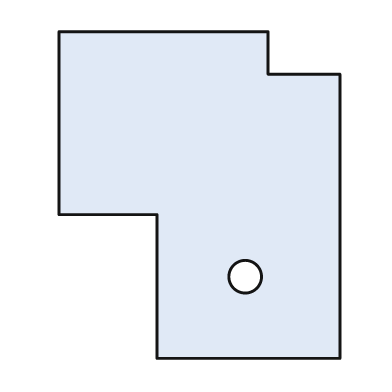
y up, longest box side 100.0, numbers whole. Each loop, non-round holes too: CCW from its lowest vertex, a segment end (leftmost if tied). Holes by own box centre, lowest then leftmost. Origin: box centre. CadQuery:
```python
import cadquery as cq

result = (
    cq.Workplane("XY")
    .moveTo(-13.0, -50.0)
    .lineTo(43.0, -50.0)
    .lineTo(43.0, 37.0)
    .lineTo(21.0, 37.0)
    .lineTo(21.0, 50.0)
    .lineTo(-43.0, 50.0)
    .lineTo(-43.0, -6.0)
    .lineTo(-13.0, -6.0)
    .close()
    .moveTo(14.0, -25.0)
    .circle(5.0)
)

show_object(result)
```